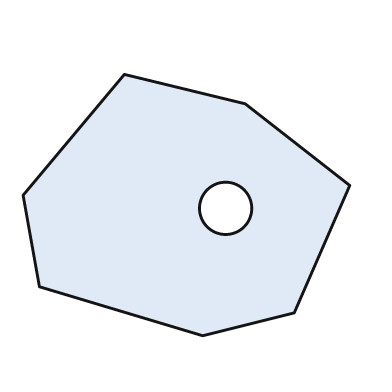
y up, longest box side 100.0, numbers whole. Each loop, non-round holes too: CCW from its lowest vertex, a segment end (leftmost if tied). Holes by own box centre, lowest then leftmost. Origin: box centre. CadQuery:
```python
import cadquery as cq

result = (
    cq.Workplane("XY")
    .moveTo(5.0, -40.0)
    .lineTo(33.0, -33.0)
    .lineTo(50.0, 6.0)
    .lineTo(18.0, 31.0)
    .lineTo(-19.0, 40.0)
    .lineTo(-50.0, 3.0)
    .lineTo(-45.0, -25.0)
    .close()
    .moveTo(12.0, -1.0)
    .circle(8.0)
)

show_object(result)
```